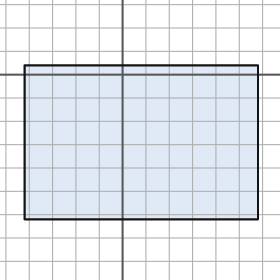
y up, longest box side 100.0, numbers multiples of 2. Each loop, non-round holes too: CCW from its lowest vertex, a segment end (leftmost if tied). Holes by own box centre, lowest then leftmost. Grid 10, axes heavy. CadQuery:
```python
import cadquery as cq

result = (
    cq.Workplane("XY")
    .moveTo(-42.0, -62.0)
    .lineTo(58.0, -62.0)
    .lineTo(58.0, 4.0)
    .lineTo(-42.0, 4.0)
    .close()
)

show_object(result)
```